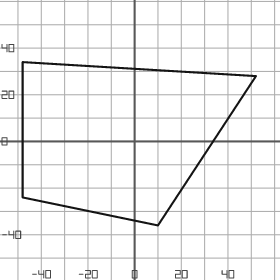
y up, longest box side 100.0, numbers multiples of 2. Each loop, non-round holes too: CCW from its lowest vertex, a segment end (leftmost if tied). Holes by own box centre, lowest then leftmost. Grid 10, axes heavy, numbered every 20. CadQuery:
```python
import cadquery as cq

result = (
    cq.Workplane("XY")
    .moveTo(10.0, -36.0)
    .lineTo(52.0, 28.0)
    .lineTo(-48.0, 34.0)
    .lineTo(-48.0, -24.0)
    .close()
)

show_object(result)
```